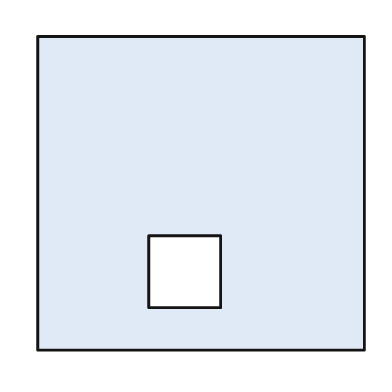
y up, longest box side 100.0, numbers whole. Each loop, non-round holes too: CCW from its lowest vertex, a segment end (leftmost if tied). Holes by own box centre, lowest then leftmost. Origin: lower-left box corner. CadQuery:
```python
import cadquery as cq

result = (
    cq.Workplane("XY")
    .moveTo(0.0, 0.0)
    .lineTo(100.0, 0.0)
    .lineTo(100.0, 96.0)
    .lineTo(0.0, 96.0)
    .close()
    .moveTo(34.0, 13.0)
    .lineTo(56.0, 13.0)
    .lineTo(56.0, 35.0)
    .lineTo(34.0, 35.0)
    .close()
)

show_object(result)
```